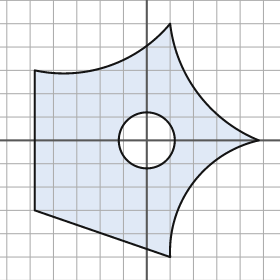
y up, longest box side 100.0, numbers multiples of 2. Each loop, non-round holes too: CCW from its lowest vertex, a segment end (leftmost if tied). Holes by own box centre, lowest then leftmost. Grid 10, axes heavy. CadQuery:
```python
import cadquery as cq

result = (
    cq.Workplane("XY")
    .moveTo(10.0, -50.0)
    .threePointArc((20.0, -18.0), (48.0, 0.0))
    .threePointArc((22.0, 20.0), (10.0, 50.0))
    .threePointArc((-16.0, 32.0), (-48.0, 30.0))
    .lineTo(-48.0, -30.0)
    .close()
    .moveTo(0.0, 0.0)
    .circle(12.0)
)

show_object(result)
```